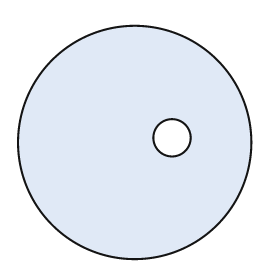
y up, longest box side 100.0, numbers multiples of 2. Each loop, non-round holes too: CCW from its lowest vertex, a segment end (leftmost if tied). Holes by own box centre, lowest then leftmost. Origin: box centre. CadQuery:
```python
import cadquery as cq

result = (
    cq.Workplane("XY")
    .moveTo(0.0, 0.0)
    .circle(50.0)
    .moveTo(16.0, 2.0)
    .circle(8.0)
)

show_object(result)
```